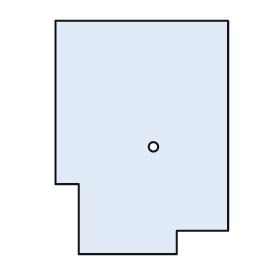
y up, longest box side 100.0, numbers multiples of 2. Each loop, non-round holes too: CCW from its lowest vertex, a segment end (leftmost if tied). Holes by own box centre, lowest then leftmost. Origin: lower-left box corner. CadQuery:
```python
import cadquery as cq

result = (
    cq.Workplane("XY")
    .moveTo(10.0, 0.0)
    .lineTo(52.0, 0.0)
    .lineTo(52.0, 10.0)
    .lineTo(74.0, 10.0)
    .lineTo(74.0, 100.0)
    .lineTo(0.0, 100.0)
    .lineTo(0.0, 30.0)
    .lineTo(10.0, 30.0)
    .close()
    .moveTo(42.0, 46.0)
    .circle(2.0)
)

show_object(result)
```